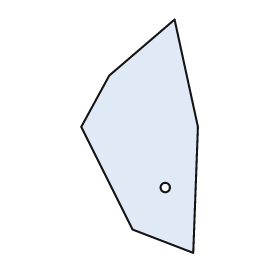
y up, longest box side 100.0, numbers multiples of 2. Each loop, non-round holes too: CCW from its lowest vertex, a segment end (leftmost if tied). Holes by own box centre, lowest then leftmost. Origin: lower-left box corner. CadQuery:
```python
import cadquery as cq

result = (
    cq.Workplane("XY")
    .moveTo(48.0, 0.0)
    .lineTo(50.0, 54.0)
    .lineTo(40.0, 100.0)
    .lineTo(12.0, 76.0)
    .lineTo(0.0, 54.0)
    .lineTo(22.0, 10.0)
    .close()
    .moveTo(36.0, 28.0)
    .circle(2.0)
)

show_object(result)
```